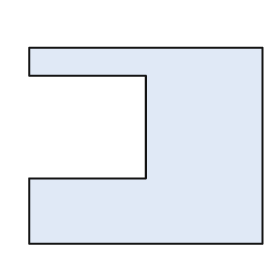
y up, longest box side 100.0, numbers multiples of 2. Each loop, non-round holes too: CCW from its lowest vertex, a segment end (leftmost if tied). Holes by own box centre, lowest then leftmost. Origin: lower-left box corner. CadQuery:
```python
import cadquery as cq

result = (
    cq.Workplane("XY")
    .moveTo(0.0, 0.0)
    .lineTo(100.0, 0.0)
    .lineTo(100.0, 84.0)
    .lineTo(0.0, 84.0)
    .lineTo(0.0, 72.0)
    .lineTo(50.0, 72.0)
    .lineTo(50.0, 28.0)
    .lineTo(0.0, 28.0)
    .close()
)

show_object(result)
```